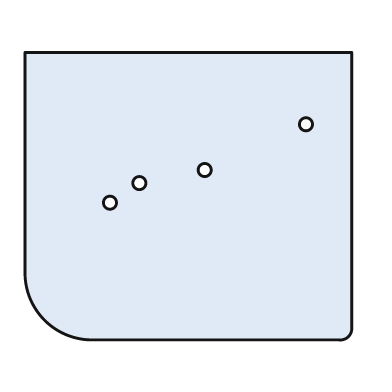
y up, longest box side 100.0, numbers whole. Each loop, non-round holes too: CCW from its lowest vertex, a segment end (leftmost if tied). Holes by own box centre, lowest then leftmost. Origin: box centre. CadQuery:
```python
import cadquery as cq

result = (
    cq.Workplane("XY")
    .moveTo(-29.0, -44.0)
    .lineTo(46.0, -44.0)
    .threePointArc((49.0, -43.0), (50.0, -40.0))
    .lineTo(50.0, 44.0)
    .lineTo(-50.0, 44.0)
    .lineTo(-50.0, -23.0)
    .threePointArc((-44.0, -38.0), (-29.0, -44.0))
    .close()
    .moveTo(-24.0, -2.0)
    .circle(2.0)
    .moveTo(-15.0, 4.0)
    .circle(2.0)
    .moveTo(5.0, 8.0)
    .circle(2.0)
    .moveTo(36.0, 22.0)
    .circle(2.0)
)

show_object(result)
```